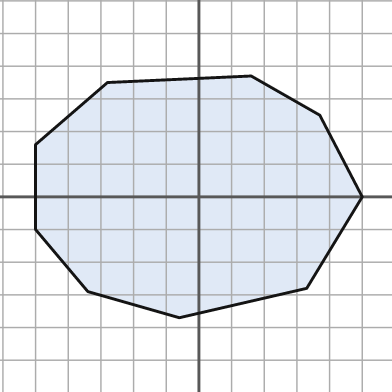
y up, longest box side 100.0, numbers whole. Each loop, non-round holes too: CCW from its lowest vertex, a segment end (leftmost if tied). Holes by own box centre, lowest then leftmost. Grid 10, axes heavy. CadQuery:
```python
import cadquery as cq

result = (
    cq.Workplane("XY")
    .moveTo(-6.0, -37.0)
    .lineTo(33.0, -28.0)
    .lineTo(50.0, 0.0)
    .lineTo(37.0, 25.0)
    .lineTo(16.0, 37.0)
    .lineTo(-28.0, 35.0)
    .lineTo(-50.0, 16.0)
    .lineTo(-50.0, -10.0)
    .lineTo(-34.0, -29.0)
    .close()
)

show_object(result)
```